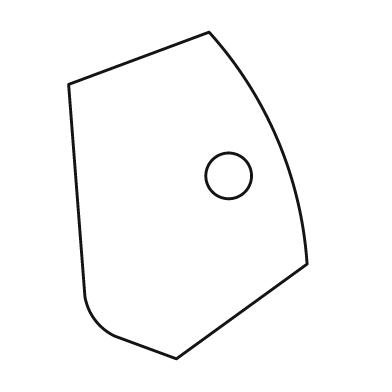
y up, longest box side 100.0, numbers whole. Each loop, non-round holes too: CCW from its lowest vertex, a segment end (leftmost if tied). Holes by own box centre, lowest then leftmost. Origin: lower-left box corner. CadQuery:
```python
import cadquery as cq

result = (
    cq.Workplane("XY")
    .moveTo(33.0, 0.0)
    .lineTo(73.0, 29.0)
    .threePointArc((64.0, 67.0), (43.0, 100.0))
    .lineTo(0.0, 84.0)
    .lineTo(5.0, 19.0)
    .threePointArc((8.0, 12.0), (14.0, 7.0))
    .close()
    .moveTo(49.0, 56.0)
    .circle(7.0)
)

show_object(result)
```